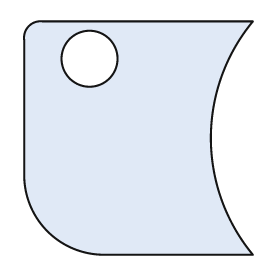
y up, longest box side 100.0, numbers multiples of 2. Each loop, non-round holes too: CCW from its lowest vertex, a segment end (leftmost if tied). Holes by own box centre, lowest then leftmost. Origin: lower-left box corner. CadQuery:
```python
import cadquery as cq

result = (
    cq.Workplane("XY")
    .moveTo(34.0, 0.0)
    .lineTo(98.0, 0.0)
    .threePointArc((80.0, 50.0), (98.0, 100.0))
    .lineTo(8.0, 100.0)
    .threePointArc((2.0, 98.0), (0.0, 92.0))
    .lineTo(0.0, 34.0)
    .threePointArc((10.0, 10.0), (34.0, 0.0))
    .close()
    .moveTo(28.0, 84.0)
    .circle(12.0)
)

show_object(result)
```